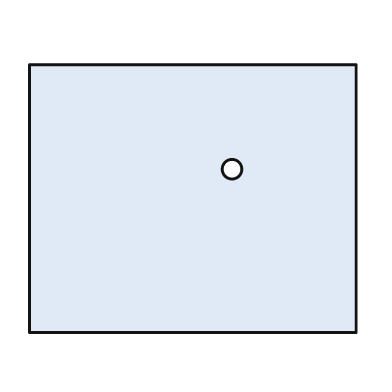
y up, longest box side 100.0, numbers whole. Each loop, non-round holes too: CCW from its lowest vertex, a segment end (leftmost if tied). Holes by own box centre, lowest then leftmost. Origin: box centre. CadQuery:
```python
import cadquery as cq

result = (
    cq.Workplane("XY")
    .moveTo(-50.0, -41.0)
    .lineTo(50.0, -41.0)
    .lineTo(50.0, 41.0)
    .lineTo(-50.0, 41.0)
    .close()
    .moveTo(12.0, 9.0)
    .circle(3.0)
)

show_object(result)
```